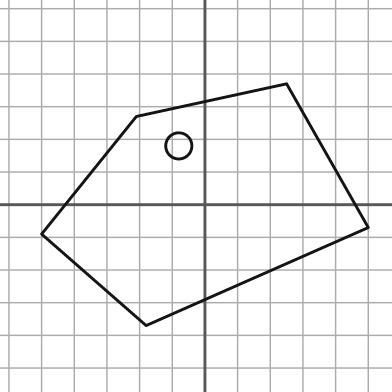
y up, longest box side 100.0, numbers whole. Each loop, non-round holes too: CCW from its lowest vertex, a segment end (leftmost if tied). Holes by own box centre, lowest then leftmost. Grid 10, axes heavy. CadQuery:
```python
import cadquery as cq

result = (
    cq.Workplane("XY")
    .moveTo(-18.0, -37.0)
    .lineTo(50.0, -7.0)
    .lineTo(25.0, 37.0)
    .lineTo(-21.0, 27.0)
    .lineTo(-50.0, -9.0)
    .close()
    .moveTo(-8.0, 18.0)
    .circle(4.0)
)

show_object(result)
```